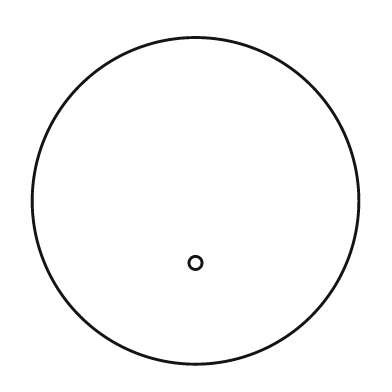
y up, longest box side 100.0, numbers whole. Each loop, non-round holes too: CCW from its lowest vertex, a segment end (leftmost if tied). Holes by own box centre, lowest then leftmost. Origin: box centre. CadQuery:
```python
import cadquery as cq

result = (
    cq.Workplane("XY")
    .moveTo(0.0, 0.0)
    .circle(50.0)
    .moveTo(0.0, -19.0)
    .circle(2.0)
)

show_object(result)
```